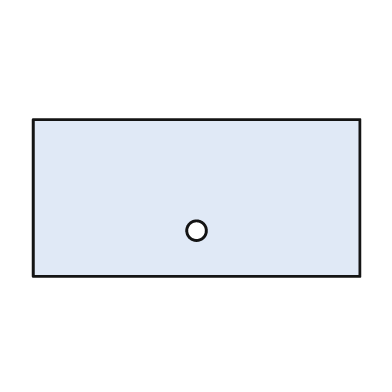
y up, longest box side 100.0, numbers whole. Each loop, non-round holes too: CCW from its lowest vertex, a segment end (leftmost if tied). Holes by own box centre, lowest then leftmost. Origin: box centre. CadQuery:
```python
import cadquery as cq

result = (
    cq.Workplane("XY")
    .moveTo(-50.0, -24.0)
    .lineTo(50.0, -24.0)
    .lineTo(50.0, 24.0)
    .lineTo(-50.0, 24.0)
    .close()
    .moveTo(0.0, -10.0)
    .circle(3.0)
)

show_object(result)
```